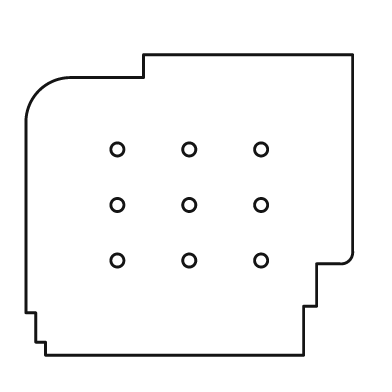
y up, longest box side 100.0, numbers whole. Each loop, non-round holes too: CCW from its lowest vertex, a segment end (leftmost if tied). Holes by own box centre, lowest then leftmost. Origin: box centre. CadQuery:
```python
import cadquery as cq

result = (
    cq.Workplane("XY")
    .moveTo(-44.0, -46.0)
    .lineTo(35.0, -46.0)
    .lineTo(35.0, -31.0)
    .lineTo(39.0, -31.0)
    .lineTo(39.0, -18.0)
    .lineTo(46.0, -18.0)
    .threePointArc((49.0, -17.0), (50.0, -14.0))
    .lineTo(50.0, 46.0)
    .lineTo(-14.0, 46.0)
    .lineTo(-14.0, 39.0)
    .lineTo(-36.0, 39.0)
    .threePointArc((-46.0, 35.0), (-50.0, 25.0))
    .lineTo(-50.0, -33.0)
    .lineTo(-47.0, -33.0)
    .lineTo(-47.0, -42.0)
    .lineTo(-44.0, -42.0)
    .close()
    .moveTo(-22.0, -17.0)
    .circle(2.0)
    .moveTo(0.0, -17.0)
    .circle(2.0)
    .moveTo(22.0, -17.0)
    .circle(2.0)
    .moveTo(-22.0, 0.0)
    .circle(2.0)
    .moveTo(0.0, 0.0)
    .circle(2.0)
    .moveTo(22.0, 0.0)
    .circle(2.0)
    .moveTo(-22.0, 17.0)
    .circle(2.0)
    .moveTo(0.0, 17.0)
    .circle(2.0)
    .moveTo(22.0, 17.0)
    .circle(2.0)
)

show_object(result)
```